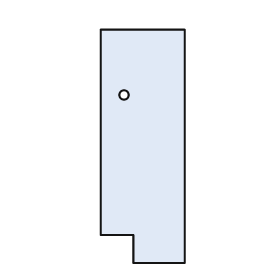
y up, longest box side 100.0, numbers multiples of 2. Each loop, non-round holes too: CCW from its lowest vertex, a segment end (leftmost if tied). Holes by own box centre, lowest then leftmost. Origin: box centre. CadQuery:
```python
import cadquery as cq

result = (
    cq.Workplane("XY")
    .moveTo(-4.0, -50.0)
    .lineTo(18.0, -50.0)
    .lineTo(18.0, 50.0)
    .lineTo(-18.0, 50.0)
    .lineTo(-18.0, -38.0)
    .lineTo(-4.0, -38.0)
    .close()
    .moveTo(-8.0, 22.0)
    .circle(2.0)
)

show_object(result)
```